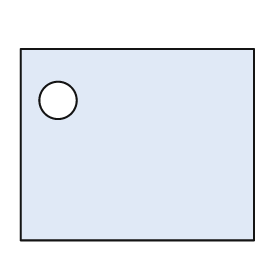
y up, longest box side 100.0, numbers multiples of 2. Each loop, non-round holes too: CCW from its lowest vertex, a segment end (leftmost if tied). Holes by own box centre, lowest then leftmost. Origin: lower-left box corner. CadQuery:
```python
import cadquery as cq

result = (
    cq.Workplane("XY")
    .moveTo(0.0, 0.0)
    .lineTo(100.0, 0.0)
    .lineTo(100.0, 82.0)
    .lineTo(0.0, 82.0)
    .close()
    .moveTo(16.0, 60.0)
    .circle(8.0)
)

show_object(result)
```